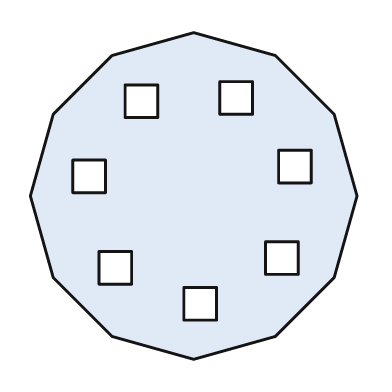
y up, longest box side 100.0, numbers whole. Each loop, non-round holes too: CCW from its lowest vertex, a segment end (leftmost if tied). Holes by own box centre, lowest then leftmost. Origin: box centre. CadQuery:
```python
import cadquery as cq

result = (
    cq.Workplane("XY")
    .moveTo(0.0, -50.0)
    .lineTo(25.0, -43.0)
    .lineTo(43.0, -25.0)
    .lineTo(50.0, 0.0)
    .lineTo(43.0, 25.0)
    .lineTo(25.0, 43.0)
    .lineTo(0.0, 50.0)
    .lineTo(-25.0, 43.0)
    .lineTo(-43.0, 25.0)
    .lineTo(-50.0, 0.0)
    .lineTo(-43.0, -25.0)
    .lineTo(-25.0, -43.0)
    .close()
    .moveTo(-3.0, -38.0)
    .lineTo(7.0, -38.0)
    .lineTo(7.0, -28.0)
    .lineTo(-3.0, -28.0)
    .close()
    .moveTo(-29.0, -27.0)
    .lineTo(-19.0, -27.0)
    .lineTo(-19.0, -17.0)
    .lineTo(-29.0, -17.0)
    .close()
    .moveTo(22.0, -24.0)
    .lineTo(32.0, -24.0)
    .lineTo(32.0, -14.0)
    .lineTo(22.0, -14.0)
    .close()
    .moveTo(-37.0, 1.0)
    .lineTo(-27.0, 1.0)
    .lineTo(-27.0, 11.0)
    .lineTo(-37.0, 11.0)
    .close()
    .moveTo(26.0, 4.0)
    .lineTo(36.0, 4.0)
    .lineTo(36.0, 14.0)
    .lineTo(26.0, 14.0)
    .close()
    .moveTo(-21.0, 24.0)
    .lineTo(-11.0, 24.0)
    .lineTo(-11.0, 34.0)
    .lineTo(-21.0, 34.0)
    .close()
    .moveTo(8.0, 25.0)
    .lineTo(18.0, 25.0)
    .lineTo(18.0, 35.0)
    .lineTo(8.0, 35.0)
    .close()
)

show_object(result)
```